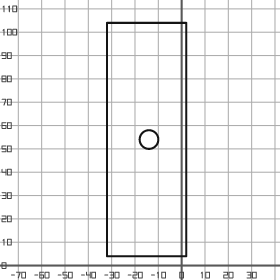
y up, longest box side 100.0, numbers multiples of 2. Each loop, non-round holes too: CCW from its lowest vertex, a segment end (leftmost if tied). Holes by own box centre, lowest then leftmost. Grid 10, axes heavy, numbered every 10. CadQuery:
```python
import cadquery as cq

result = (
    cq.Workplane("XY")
    .moveTo(-32.0, 4.0)
    .lineTo(2.0, 4.0)
    .lineTo(2.0, 104.0)
    .lineTo(-32.0, 104.0)
    .close()
    .moveTo(-14.0, 54.0)
    .circle(4.0)
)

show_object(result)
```